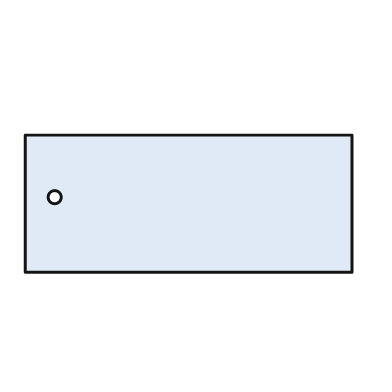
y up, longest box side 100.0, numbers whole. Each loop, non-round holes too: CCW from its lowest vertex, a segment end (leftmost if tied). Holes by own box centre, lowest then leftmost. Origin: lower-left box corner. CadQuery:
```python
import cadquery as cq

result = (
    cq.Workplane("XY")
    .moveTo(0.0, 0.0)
    .lineTo(100.0, 0.0)
    .lineTo(100.0, 42.0)
    .lineTo(0.0, 42.0)
    .close()
    .moveTo(9.0, 23.0)
    .circle(2.0)
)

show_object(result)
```